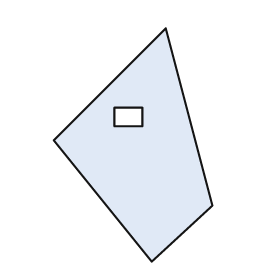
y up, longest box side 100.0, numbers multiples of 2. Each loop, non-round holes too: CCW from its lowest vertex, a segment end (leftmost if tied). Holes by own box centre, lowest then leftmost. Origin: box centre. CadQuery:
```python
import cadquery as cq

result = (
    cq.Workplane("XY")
    .moveTo(8.0, -50.0)
    .lineTo(34.0, -26.0)
    .lineTo(14.0, 50.0)
    .lineTo(-34.0, 2.0)
    .close()
    .moveTo(-8.0, 8.0)
    .lineTo(4.0, 8.0)
    .lineTo(4.0, 16.0)
    .lineTo(-8.0, 16.0)
    .close()
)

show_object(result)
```